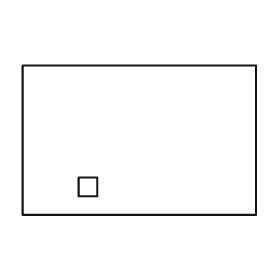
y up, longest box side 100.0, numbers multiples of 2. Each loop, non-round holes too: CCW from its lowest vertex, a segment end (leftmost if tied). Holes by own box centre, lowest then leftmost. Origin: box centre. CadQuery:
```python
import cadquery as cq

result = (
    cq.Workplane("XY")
    .moveTo(-50.0, -32.0)
    .lineTo(50.0, -32.0)
    .lineTo(50.0, 32.0)
    .lineTo(-50.0, 32.0)
    .close()
    .moveTo(-26.0, -24.0)
    .lineTo(-18.0, -24.0)
    .lineTo(-18.0, -16.0)
    .lineTo(-26.0, -16.0)
    .close()
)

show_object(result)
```